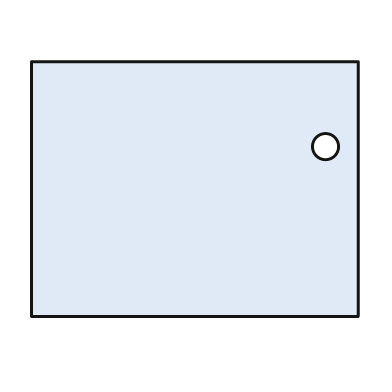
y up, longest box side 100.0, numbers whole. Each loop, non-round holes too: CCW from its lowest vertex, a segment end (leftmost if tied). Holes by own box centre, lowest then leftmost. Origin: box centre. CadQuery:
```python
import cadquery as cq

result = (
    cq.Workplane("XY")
    .moveTo(-50.0, -39.0)
    .lineTo(50.0, -39.0)
    .lineTo(50.0, 39.0)
    .lineTo(-50.0, 39.0)
    .close()
    .moveTo(40.0, 13.0)
    .circle(4.0)
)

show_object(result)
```